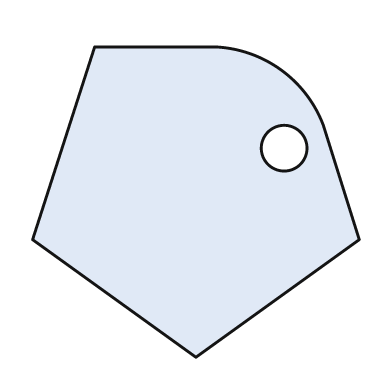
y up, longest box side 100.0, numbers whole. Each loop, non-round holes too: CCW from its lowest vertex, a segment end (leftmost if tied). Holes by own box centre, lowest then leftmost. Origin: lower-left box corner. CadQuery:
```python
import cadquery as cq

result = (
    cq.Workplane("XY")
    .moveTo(50.0, 0.0)
    .lineTo(100.0, 36.0)
    .lineTo(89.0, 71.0)
    .threePointArc((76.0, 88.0), (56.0, 95.0))
    .lineTo(19.0, 95.0)
    .lineTo(0.0, 36.0)
    .close()
    .moveTo(77.0, 64.0)
    .circle(7.0)
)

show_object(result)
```